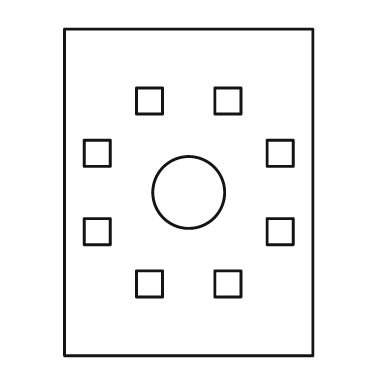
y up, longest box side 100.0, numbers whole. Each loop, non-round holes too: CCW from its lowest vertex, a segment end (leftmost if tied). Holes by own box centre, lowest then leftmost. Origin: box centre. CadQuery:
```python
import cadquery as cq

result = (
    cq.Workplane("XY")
    .moveTo(-38.0, -50.0)
    .lineTo(38.0, -50.0)
    .lineTo(38.0, 50.0)
    .lineTo(-38.0, 50.0)
    .close()
    .moveTo(-16.0, -32.0)
    .lineTo(-8.0, -32.0)
    .lineTo(-8.0, -24.0)
    .lineTo(-16.0, -24.0)
    .close()
    .moveTo(8.0, -32.0)
    .lineTo(16.0, -32.0)
    .lineTo(16.0, -24.0)
    .lineTo(8.0, -24.0)
    .close()
    .moveTo(-32.0, -16.0)
    .lineTo(-24.0, -16.0)
    .lineTo(-24.0, -8.0)
    .lineTo(-32.0, -8.0)
    .close()
    .moveTo(24.0, -16.0)
    .lineTo(32.0, -16.0)
    .lineTo(32.0, -8.0)
    .lineTo(24.0, -8.0)
    .close()
    .moveTo(0.0, 0.0)
    .circle(11.0)
    .moveTo(-32.0, 8.0)
    .lineTo(-24.0, 8.0)
    .lineTo(-24.0, 16.0)
    .lineTo(-32.0, 16.0)
    .close()
    .moveTo(24.0, 8.0)
    .lineTo(32.0, 8.0)
    .lineTo(32.0, 16.0)
    .lineTo(24.0, 16.0)
    .close()
    .moveTo(-16.0, 24.0)
    .lineTo(-8.0, 24.0)
    .lineTo(-8.0, 32.0)
    .lineTo(-16.0, 32.0)
    .close()
    .moveTo(8.0, 24.0)
    .lineTo(16.0, 24.0)
    .lineTo(16.0, 32.0)
    .lineTo(8.0, 32.0)
    .close()
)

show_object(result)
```